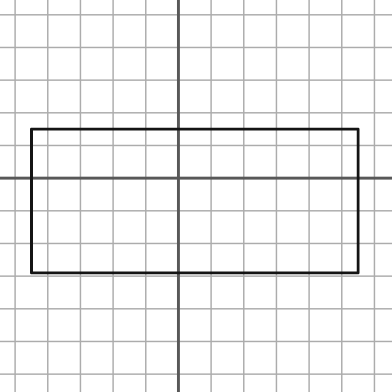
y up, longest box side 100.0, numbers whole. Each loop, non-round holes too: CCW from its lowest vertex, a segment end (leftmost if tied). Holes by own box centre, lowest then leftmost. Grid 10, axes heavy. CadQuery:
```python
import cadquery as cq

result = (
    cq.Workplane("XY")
    .moveTo(-45.0, -29.0)
    .lineTo(55.0, -29.0)
    .lineTo(55.0, 15.0)
    .lineTo(-45.0, 15.0)
    .close()
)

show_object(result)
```